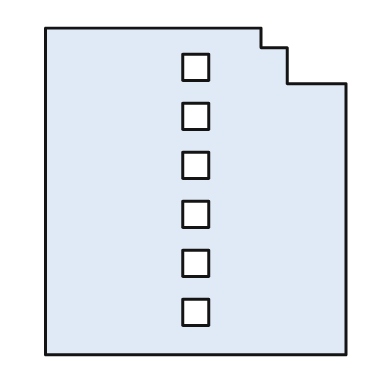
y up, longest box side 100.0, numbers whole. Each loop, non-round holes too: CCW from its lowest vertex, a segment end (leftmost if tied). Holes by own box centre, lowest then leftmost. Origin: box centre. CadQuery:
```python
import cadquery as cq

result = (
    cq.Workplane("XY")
    .moveTo(-46.0, -50.0)
    .lineTo(46.0, -50.0)
    .lineTo(46.0, 33.0)
    .lineTo(28.0, 33.0)
    .lineTo(28.0, 44.0)
    .lineTo(20.0, 44.0)
    .lineTo(20.0, 50.0)
    .lineTo(-46.0, 50.0)
    .close()
    .moveTo(-4.0, -41.0)
    .lineTo(4.0, -41.0)
    .lineTo(4.0, -33.0)
    .lineTo(-4.0, -33.0)
    .close()
    .moveTo(-4.0, -26.0)
    .lineTo(4.0, -26.0)
    .lineTo(4.0, -18.0)
    .lineTo(-4.0, -18.0)
    .close()
    .moveTo(-4.0, -11.0)
    .lineTo(4.0, -11.0)
    .lineTo(4.0, -3.0)
    .lineTo(-4.0, -3.0)
    .close()
    .moveTo(-4.0, 4.0)
    .lineTo(4.0, 4.0)
    .lineTo(4.0, 12.0)
    .lineTo(-4.0, 12.0)
    .close()
    .moveTo(-4.0, 19.0)
    .lineTo(4.0, 19.0)
    .lineTo(4.0, 27.0)
    .lineTo(-4.0, 27.0)
    .close()
    .moveTo(-4.0, 34.0)
    .lineTo(4.0, 34.0)
    .lineTo(4.0, 42.0)
    .lineTo(-4.0, 42.0)
    .close()
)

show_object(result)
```